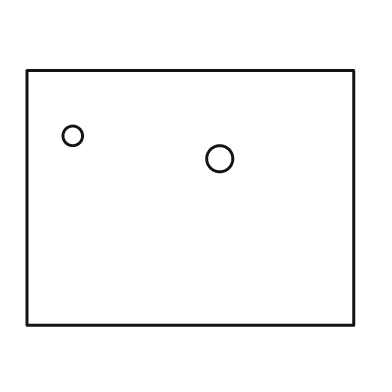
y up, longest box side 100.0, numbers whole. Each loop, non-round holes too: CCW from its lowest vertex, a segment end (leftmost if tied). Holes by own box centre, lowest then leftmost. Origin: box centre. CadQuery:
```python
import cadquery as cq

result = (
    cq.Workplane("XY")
    .moveTo(-50.0, -39.0)
    .lineTo(50.0, -39.0)
    .lineTo(50.0, 39.0)
    .lineTo(-50.0, 39.0)
    .close()
    .moveTo(9.0, 12.0)
    .circle(4.0)
    .moveTo(-36.0, 19.0)
    .circle(3.0)
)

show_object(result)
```